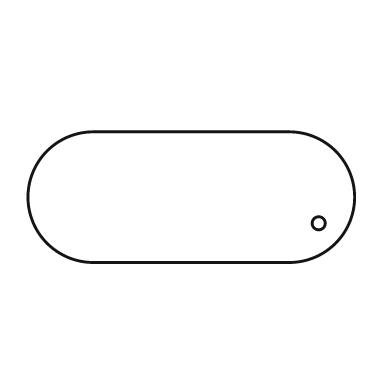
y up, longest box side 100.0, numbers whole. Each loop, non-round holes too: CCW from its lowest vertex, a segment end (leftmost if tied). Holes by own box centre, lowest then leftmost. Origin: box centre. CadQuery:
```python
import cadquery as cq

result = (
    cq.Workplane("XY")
    .moveTo(-30.0, -20.0)
    .lineTo(30.0, -20.0)
    .threePointArc((50.0, 0.0), (30.0, 20.0))
    .lineTo(-30.0, 20.0)
    .threePointArc((-50.0, 0.0), (-30.0, -20.0))
    .close()
    .moveTo(39.0, -8.0)
    .circle(2.0)
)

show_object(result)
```